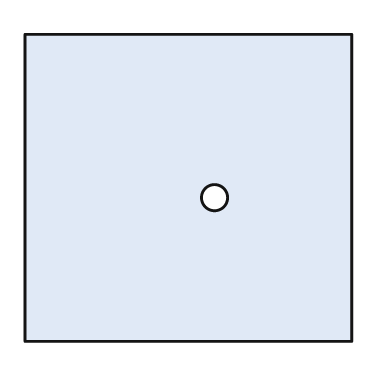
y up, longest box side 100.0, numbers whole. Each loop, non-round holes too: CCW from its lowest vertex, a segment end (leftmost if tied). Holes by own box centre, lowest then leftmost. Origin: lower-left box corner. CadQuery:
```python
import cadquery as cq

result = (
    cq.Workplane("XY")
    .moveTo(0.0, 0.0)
    .lineTo(100.0, 0.0)
    .lineTo(100.0, 94.0)
    .lineTo(0.0, 94.0)
    .close()
    .moveTo(58.0, 44.0)
    .circle(4.0)
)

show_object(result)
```